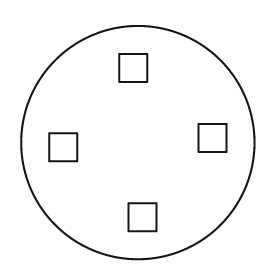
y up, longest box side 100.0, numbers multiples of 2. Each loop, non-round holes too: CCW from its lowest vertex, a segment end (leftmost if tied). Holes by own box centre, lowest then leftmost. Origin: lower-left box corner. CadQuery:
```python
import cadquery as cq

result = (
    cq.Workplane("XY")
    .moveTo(50.0, 50.0)
    .circle(50.0)
    .moveTo(46.0, 12.0)
    .lineTo(58.0, 12.0)
    .lineTo(58.0, 24.0)
    .lineTo(46.0, 24.0)
    .close()
    .moveTo(12.0, 42.0)
    .lineTo(24.0, 42.0)
    .lineTo(24.0, 54.0)
    .lineTo(12.0, 54.0)
    .close()
    .moveTo(76.0, 46.0)
    .lineTo(88.0, 46.0)
    .lineTo(88.0, 58.0)
    .lineTo(76.0, 58.0)
    .close()
    .moveTo(42.0, 76.0)
    .lineTo(54.0, 76.0)
    .lineTo(54.0, 88.0)
    .lineTo(42.0, 88.0)
    .close()
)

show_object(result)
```